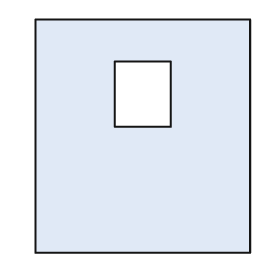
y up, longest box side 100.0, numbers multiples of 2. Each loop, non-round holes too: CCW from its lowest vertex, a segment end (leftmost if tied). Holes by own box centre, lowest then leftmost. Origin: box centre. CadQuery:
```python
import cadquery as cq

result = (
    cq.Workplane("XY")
    .moveTo(-46.0, -50.0)
    .lineTo(46.0, -50.0)
    .lineTo(46.0, 50.0)
    .lineTo(-46.0, 50.0)
    .close()
    .moveTo(-12.0, 4.0)
    .lineTo(12.0, 4.0)
    .lineTo(12.0, 32.0)
    .lineTo(-12.0, 32.0)
    .close()
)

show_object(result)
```